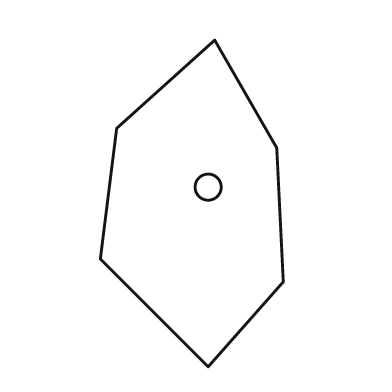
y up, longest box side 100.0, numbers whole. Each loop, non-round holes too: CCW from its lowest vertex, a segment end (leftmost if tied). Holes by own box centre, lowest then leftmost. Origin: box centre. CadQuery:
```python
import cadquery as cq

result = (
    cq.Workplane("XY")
    .moveTo(5.0, -50.0)
    .lineTo(28.0, -24.0)
    .lineTo(26.0, 17.0)
    .lineTo(7.0, 50.0)
    .lineTo(-23.0, 23.0)
    .lineTo(-28.0, -17.0)
    .close()
    .moveTo(5.0, 5.0)
    .circle(4.0)
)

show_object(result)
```